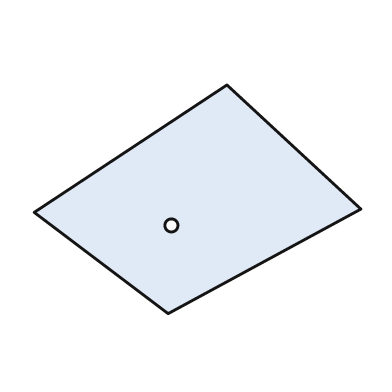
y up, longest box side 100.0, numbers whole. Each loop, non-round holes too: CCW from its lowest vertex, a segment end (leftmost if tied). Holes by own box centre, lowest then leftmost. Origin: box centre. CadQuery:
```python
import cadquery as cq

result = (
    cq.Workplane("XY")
    .moveTo(-9.0, -35.0)
    .lineTo(50.0, -3.0)
    .lineTo(9.0, 35.0)
    .lineTo(-50.0, -4.0)
    .close()
    .moveTo(-8.0, -8.0)
    .circle(2.0)
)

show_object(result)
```